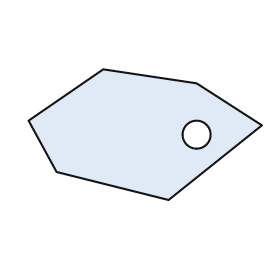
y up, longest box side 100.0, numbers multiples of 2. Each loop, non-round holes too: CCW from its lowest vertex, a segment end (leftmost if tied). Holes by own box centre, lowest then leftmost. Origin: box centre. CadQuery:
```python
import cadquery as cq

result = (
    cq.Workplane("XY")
    .moveTo(10.0, -28.0)
    .lineTo(50.0, 4.0)
    .lineTo(22.0, 22.0)
    .lineTo(-18.0, 28.0)
    .lineTo(-50.0, 6.0)
    .lineTo(-38.0, -16.0)
    .close()
    .moveTo(22.0, 0.0)
    .circle(6.0)
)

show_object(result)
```